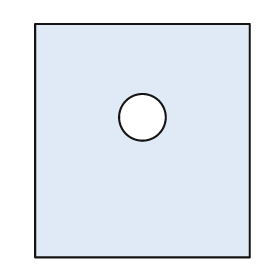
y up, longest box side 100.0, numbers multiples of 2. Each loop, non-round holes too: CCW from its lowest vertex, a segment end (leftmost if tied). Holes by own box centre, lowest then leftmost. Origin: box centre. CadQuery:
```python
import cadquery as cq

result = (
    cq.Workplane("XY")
    .moveTo(-46.0, -50.0)
    .lineTo(46.0, -50.0)
    .lineTo(46.0, 50.0)
    .lineTo(-46.0, 50.0)
    .close()
    .moveTo(0.0, 10.0)
    .circle(10.0)
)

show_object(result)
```